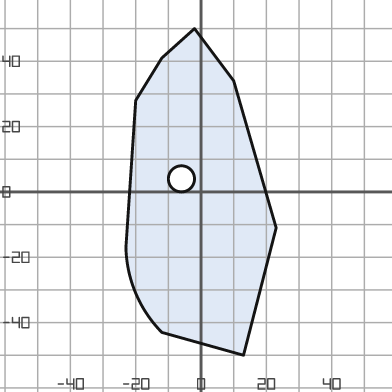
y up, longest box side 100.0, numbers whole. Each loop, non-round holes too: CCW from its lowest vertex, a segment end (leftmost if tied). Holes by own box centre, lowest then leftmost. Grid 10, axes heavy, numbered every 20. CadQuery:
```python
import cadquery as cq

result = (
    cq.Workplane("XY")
    .moveTo(13.0, -50.0)
    .lineTo(23.0, -11.0)
    .lineTo(10.0, 34.0)
    .lineTo(-2.0, 50.0)
    .lineTo(-12.0, 41.0)
    .lineTo(-20.0, 28.0)
    .lineTo(-23.0, -17.0)
    .threePointArc((-20.0, -31.0), (-12.0, -43.0))
    .close()
    .moveTo(-6.0, 4.0)
    .circle(4.0)
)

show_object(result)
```